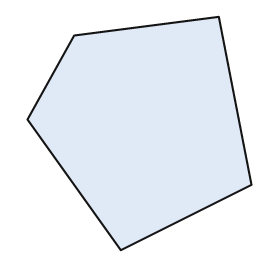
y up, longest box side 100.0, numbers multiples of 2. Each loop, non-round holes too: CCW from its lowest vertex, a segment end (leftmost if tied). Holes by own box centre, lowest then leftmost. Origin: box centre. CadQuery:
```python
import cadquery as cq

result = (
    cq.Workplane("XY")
    .moveTo(-8.0, -50.0)
    .lineTo(48.0, -22.0)
    .lineTo(34.0, 50.0)
    .lineTo(-28.0, 42.0)
    .lineTo(-48.0, 6.0)
    .close()
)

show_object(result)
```